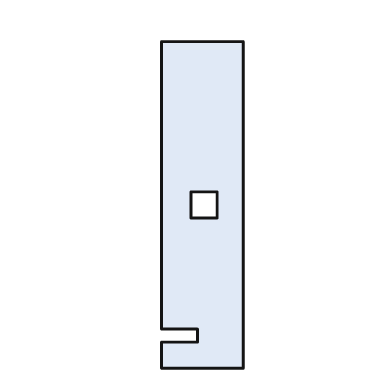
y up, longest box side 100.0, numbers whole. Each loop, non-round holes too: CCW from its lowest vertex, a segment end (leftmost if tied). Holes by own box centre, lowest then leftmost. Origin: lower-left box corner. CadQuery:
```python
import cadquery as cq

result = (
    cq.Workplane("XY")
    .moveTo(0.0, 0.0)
    .lineTo(25.0, 0.0)
    .lineTo(25.0, 100.0)
    .lineTo(0.0, 100.0)
    .lineTo(0.0, 12.0)
    .lineTo(11.0, 12.0)
    .lineTo(11.0, 8.0)
    .lineTo(0.0, 8.0)
    .close()
    .moveTo(9.0, 46.0)
    .lineTo(17.0, 46.0)
    .lineTo(17.0, 54.0)
    .lineTo(9.0, 54.0)
    .close()
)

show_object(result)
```